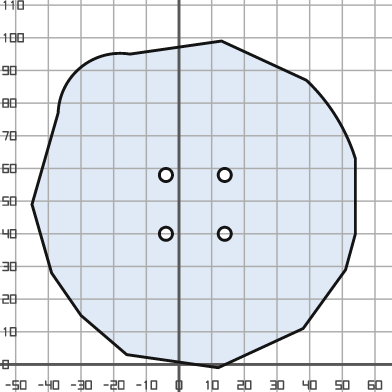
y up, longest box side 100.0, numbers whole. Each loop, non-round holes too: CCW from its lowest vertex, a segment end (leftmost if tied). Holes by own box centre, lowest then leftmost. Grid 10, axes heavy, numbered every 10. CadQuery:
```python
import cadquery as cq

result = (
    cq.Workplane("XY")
    .moveTo(12.0, -1.0)
    .lineTo(38.0, 11.0)
    .lineTo(51.0, 29.0)
    .lineTo(54.0, 40.0)
    .lineTo(54.0, 63.0)
    .threePointArc((48.0, 76.0), (39.0, 87.0))
    .lineTo(13.0, 99.0)
    .lineTo(-15.0, 95.0)
    .threePointArc((-30.0, 91.0), (-37.0, 77.0))
    .lineTo(-45.0, 49.0)
    .lineTo(-39.0, 28.0)
    .lineTo(-30.0, 15.0)
    .lineTo(-16.0, 3.0)
    .close()
    .moveTo(-4.0, 40.0)
    .circle(2.0)
    .moveTo(14.0, 40.0)
    .circle(2.0)
    .moveTo(-4.0, 58.0)
    .circle(2.0)
    .moveTo(14.0, 58.0)
    .circle(2.0)
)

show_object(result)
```